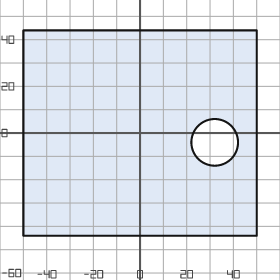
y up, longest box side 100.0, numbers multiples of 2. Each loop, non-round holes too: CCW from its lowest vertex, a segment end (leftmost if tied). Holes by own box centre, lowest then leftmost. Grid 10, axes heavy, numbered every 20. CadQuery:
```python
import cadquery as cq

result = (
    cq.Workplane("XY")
    .moveTo(-50.0, -44.0)
    .lineTo(50.0, -44.0)
    .lineTo(50.0, 44.0)
    .lineTo(-50.0, 44.0)
    .close()
    .moveTo(32.0, -4.0)
    .circle(10.0)
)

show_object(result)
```